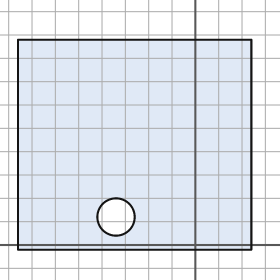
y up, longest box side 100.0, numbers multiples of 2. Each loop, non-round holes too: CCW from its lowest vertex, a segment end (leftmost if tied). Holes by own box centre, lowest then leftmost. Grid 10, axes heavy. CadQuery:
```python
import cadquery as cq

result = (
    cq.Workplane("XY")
    .moveTo(-76.0, -2.0)
    .lineTo(24.0, -2.0)
    .lineTo(24.0, 88.0)
    .lineTo(-76.0, 88.0)
    .close()
    .moveTo(-34.0, 12.0)
    .circle(8.0)
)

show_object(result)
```